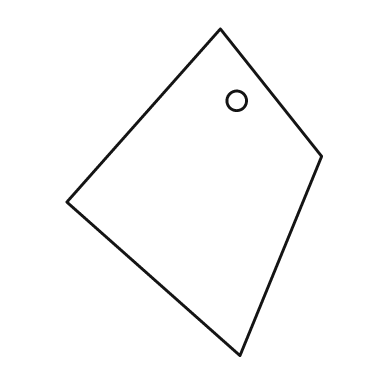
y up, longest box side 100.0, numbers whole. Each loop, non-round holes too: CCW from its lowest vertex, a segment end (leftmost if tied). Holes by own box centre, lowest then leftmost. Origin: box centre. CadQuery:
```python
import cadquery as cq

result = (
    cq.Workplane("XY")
    .moveTo(14.0, -50.0)
    .lineTo(39.0, 11.0)
    .lineTo(8.0, 50.0)
    .lineTo(-39.0, -3.0)
    .close()
    .moveTo(13.0, 28.0)
    .circle(3.0)
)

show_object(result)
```